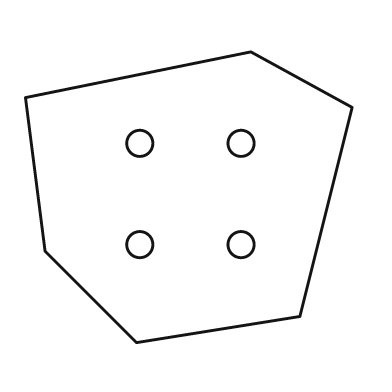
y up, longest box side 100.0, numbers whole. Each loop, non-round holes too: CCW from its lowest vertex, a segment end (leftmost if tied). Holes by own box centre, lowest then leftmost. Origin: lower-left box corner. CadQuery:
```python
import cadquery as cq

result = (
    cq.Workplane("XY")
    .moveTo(34.0, 0.0)
    .lineTo(84.0, 8.0)
    .lineTo(100.0, 72.0)
    .lineTo(69.0, 89.0)
    .lineTo(0.0, 75.0)
    .lineTo(6.0, 28.0)
    .close()
    .moveTo(35.0, 30.0)
    .circle(4.0)
    .moveTo(66.0, 30.0)
    .circle(4.0)
    .moveTo(35.0, 61.0)
    .circle(4.0)
    .moveTo(66.0, 61.0)
    .circle(4.0)
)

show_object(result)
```